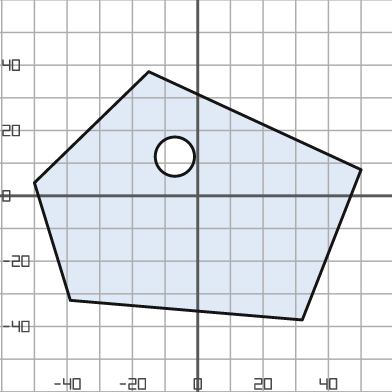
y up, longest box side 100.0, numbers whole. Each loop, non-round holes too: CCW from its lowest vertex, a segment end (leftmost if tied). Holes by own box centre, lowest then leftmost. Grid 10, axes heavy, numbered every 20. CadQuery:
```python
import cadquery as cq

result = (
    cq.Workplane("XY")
    .moveTo(32.0, -38.0)
    .lineTo(50.0, 8.0)
    .lineTo(-15.0, 38.0)
    .lineTo(-50.0, 4.0)
    .lineTo(-39.0, -32.0)
    .close()
    .moveTo(-7.0, 12.0)
    .circle(6.0)
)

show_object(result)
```